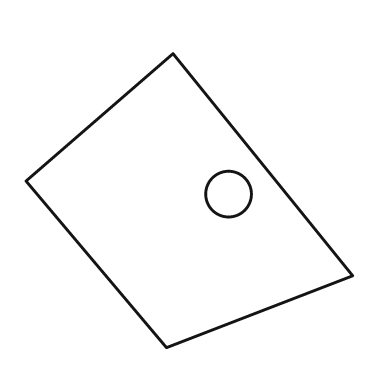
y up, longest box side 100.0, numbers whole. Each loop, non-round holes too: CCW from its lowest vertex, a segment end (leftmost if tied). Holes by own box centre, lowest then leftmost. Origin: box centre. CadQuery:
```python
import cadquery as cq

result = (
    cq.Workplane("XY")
    .moveTo(-7.0, -45.0)
    .lineTo(50.0, -23.0)
    .lineTo(-5.0, 45.0)
    .lineTo(-50.0, 6.0)
    .close()
    .moveTo(12.0, 2.0)
    .circle(7.0)
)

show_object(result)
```